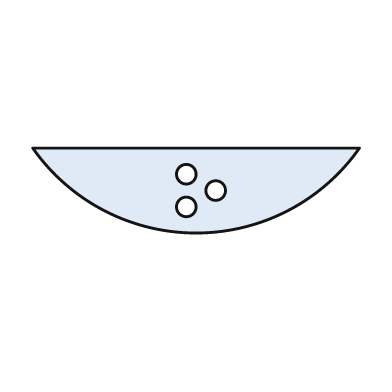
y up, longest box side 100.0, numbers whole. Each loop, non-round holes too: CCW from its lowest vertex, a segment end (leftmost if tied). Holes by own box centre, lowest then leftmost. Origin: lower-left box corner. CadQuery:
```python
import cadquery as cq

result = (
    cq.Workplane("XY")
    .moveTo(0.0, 26.0)
    .threePointArc((50.0, 0.0), (100.0, 26.0))
    .close()
    .moveTo(47.0, 8.0)
    .circle(3.0)
    .moveTo(56.0, 13.0)
    .circle(3.0)
    .moveTo(47.0, 18.0)
    .circle(3.0)
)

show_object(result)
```